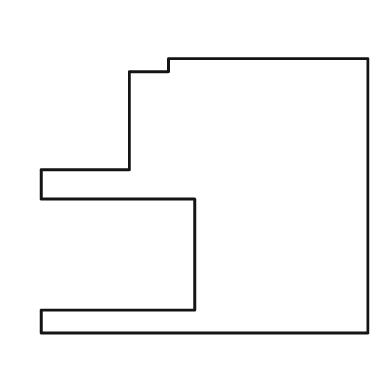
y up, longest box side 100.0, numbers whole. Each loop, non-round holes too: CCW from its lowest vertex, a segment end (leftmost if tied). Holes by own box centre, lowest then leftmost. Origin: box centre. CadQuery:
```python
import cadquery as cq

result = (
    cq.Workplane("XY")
    .moveTo(-50.0, -42.0)
    .lineTo(50.0, -42.0)
    .lineTo(50.0, 42.0)
    .lineTo(-11.0, 42.0)
    .lineTo(-11.0, 38.0)
    .lineTo(-23.0, 38.0)
    .lineTo(-23.0, 8.0)
    .lineTo(-50.0, 8.0)
    .lineTo(-50.0, -1.0)
    .lineTo(-3.0, -1.0)
    .lineTo(-3.0, -35.0)
    .lineTo(-50.0, -35.0)
    .close()
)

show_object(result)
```